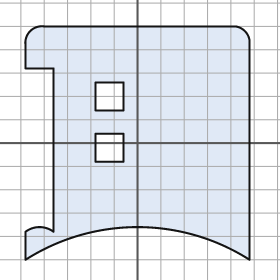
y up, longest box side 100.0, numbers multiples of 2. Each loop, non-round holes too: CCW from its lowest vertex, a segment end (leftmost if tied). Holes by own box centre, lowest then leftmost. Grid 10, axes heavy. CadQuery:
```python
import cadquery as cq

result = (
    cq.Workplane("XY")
    .moveTo(-48.0, -50.0)
    .threePointArc((0.0, -36.0), (48.0, -50.0))
    .lineTo(48.0, 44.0)
    .threePointArc((46.0, 48.0), (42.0, 50.0))
    .lineTo(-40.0, 50.0)
    .threePointArc((-46.0, 48.0), (-48.0, 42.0))
    .lineTo(-48.0, 32.0)
    .lineTo(-36.0, 32.0)
    .lineTo(-36.0, -38.0)
    .threePointArc((-42.0, -36.0), (-48.0, -38.0))
    .close()
    .moveTo(-18.0, -8.0)
    .lineTo(-6.0, -8.0)
    .lineTo(-6.0, 4.0)
    .lineTo(-18.0, 4.0)
    .close()
    .moveTo(-18.0, 14.0)
    .lineTo(-6.0, 14.0)
    .lineTo(-6.0, 26.0)
    .lineTo(-18.0, 26.0)
    .close()
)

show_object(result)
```